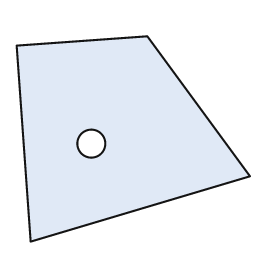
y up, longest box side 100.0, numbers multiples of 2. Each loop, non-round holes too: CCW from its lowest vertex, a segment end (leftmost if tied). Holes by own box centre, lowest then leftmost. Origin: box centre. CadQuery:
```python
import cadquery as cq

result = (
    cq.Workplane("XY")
    .moveTo(-44.0, -44.0)
    .lineTo(50.0, -16.0)
    .lineTo(6.0, 44.0)
    .lineTo(-50.0, 40.0)
    .close()
    .moveTo(-18.0, -2.0)
    .circle(6.0)
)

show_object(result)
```